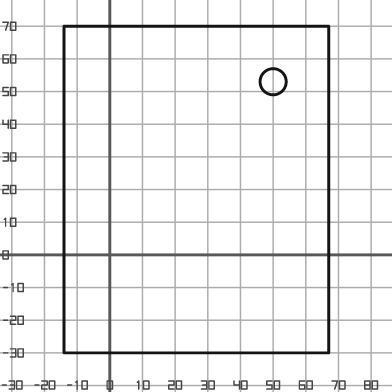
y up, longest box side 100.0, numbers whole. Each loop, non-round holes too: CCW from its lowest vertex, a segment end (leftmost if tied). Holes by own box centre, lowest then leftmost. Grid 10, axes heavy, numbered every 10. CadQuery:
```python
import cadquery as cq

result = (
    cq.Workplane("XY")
    .moveTo(-14.0, -30.0)
    .lineTo(67.0, -30.0)
    .lineTo(67.0, 70.0)
    .lineTo(-14.0, 70.0)
    .close()
    .moveTo(50.0, 53.0)
    .circle(4.0)
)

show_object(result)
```